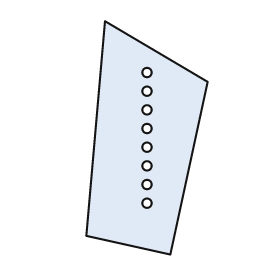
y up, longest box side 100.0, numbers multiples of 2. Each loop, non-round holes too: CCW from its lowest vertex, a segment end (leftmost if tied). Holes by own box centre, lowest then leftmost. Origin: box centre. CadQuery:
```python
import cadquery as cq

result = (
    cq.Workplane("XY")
    .moveTo(10.0, -50.0)
    .lineTo(26.0, 24.0)
    .lineTo(-18.0, 50.0)
    .lineTo(-26.0, -42.0)
    .close()
    .moveTo(0.0, -28.0)
    .circle(2.0)
    .moveTo(0.0, -20.0)
    .circle(2.0)
    .moveTo(0.0, -12.0)
    .circle(2.0)
    .moveTo(0.0, -4.0)
    .circle(2.0)
    .moveTo(0.0, 4.0)
    .circle(2.0)
    .moveTo(0.0, 12.0)
    .circle(2.0)
    .moveTo(0.0, 20.0)
    .circle(2.0)
    .moveTo(0.0, 28.0)
    .circle(2.0)
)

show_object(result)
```